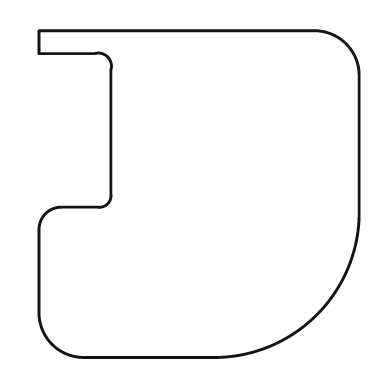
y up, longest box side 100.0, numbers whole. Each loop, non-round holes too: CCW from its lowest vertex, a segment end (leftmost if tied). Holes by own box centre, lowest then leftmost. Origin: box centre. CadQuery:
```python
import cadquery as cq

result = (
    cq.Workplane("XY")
    .moveTo(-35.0, -50.0)
    .lineTo(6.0, -50.0)
    .threePointArc((36.0, -37.0), (49.0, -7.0))
    .lineTo(49.0, 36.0)
    .threePointArc((45.0, 46.0), (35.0, 50.0))
    .lineTo(-49.0, 50.0)
    .lineTo(-49.0, 43.0)
    .lineTo(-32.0, 43.0)
    .threePointArc((-28.0, 42.0), (-27.0, 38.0))
    .lineTo(-27.0, 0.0)
    .threePointArc((-28.0, -3.0), (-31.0, -4.0))
    .lineTo(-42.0, -4.0)
    .threePointArc((-47.0, -6.0), (-49.0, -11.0))
    .lineTo(-49.0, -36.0)
    .threePointArc((-45.0, -46.0), (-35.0, -50.0))
    .close()
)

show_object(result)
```